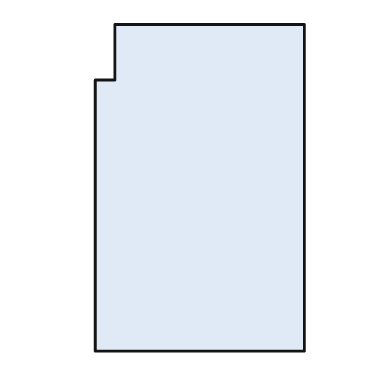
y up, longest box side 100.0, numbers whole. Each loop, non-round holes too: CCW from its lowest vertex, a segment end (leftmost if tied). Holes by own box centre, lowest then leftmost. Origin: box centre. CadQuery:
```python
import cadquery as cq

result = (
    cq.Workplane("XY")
    .moveTo(-32.0, -50.0)
    .lineTo(32.0, -50.0)
    .lineTo(32.0, 50.0)
    .lineTo(-26.0, 50.0)
    .lineTo(-26.0, 33.0)
    .lineTo(-32.0, 33.0)
    .close()
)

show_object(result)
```